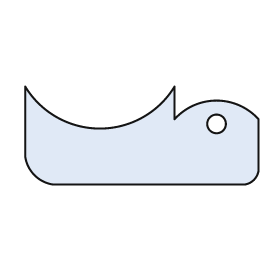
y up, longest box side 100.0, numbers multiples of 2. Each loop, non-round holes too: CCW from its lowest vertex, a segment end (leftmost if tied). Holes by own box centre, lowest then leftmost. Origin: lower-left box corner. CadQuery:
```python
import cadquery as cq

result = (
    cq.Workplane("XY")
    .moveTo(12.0, 0.0)
    .lineTo(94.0, 0.0)
    .threePointArc((98.0, 2.0), (100.0, 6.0))
    .lineTo(100.0, 28.0)
    .threePointArc((82.0, 36.0), (64.0, 28.0))
    .lineTo(64.0, 42.0)
    .threePointArc((32.0, 24.0), (0.0, 42.0))
    .lineTo(0.0, 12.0)
    .threePointArc((4.0, 4.0), (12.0, 0.0))
    .close()
    .moveTo(82.0, 26.0)
    .circle(4.0)
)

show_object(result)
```